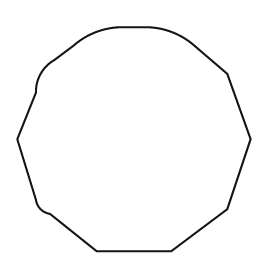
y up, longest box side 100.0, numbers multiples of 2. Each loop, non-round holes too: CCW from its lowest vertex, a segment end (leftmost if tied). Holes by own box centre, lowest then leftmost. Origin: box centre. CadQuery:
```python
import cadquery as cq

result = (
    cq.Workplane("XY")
    .moveTo(-16.0, -48.0)
    .lineTo(16.0, -48.0)
    .lineTo(40.0, -30.0)
    .lineTo(50.0, 0.0)
    .lineTo(40.0, 28.0)
    .lineTo(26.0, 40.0)
    .threePointArc((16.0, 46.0), (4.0, 48.0))
    .lineTo(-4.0, 48.0)
    .threePointArc((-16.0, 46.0), (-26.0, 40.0))
    .lineTo(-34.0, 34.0)
    .threePointArc((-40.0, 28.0), (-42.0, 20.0))
    .lineTo(-50.0, 0.0)
    .lineTo(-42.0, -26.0)
    .threePointArc((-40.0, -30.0), (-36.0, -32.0))
    .close()
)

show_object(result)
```